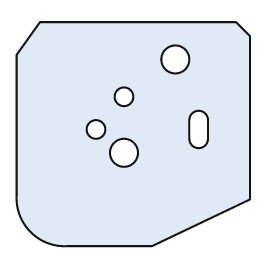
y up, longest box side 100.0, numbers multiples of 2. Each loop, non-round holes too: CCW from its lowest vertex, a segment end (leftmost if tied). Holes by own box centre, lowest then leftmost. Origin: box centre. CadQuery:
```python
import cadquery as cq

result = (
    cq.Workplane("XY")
    .moveTo(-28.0, -48.0)
    .lineTo(8.0, -48.0)
    .lineTo(50.0, -28.0)
    .lineTo(50.0, 42.0)
    .lineTo(44.0, 48.0)
    .lineTo(-40.0, 48.0)
    .lineTo(-50.0, 34.0)
    .lineTo(-50.0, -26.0)
    .threePointArc((-44.0, -42.0), (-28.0, -48.0))
    .close()
    .moveTo(-4.0, -8.0)
    .circle(6.0)
    .moveTo(-16.0, 2.0)
    .circle(4.0)
    .moveTo(24.0, -2.0)
    .threePointArc((28.0, -6.0), (32.0, -2.0))
    .lineTo(32.0, 6.0)
    .threePointArc((28.0, 10.0), (24.0, 6.0))
    .close()
    .moveTo(-4.0, 16.0)
    .circle(4.0)
    .moveTo(18.0, 32.0)
    .circle(6.0)
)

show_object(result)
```